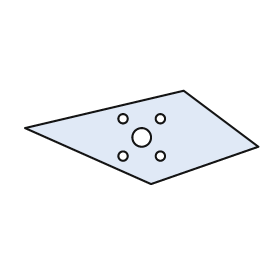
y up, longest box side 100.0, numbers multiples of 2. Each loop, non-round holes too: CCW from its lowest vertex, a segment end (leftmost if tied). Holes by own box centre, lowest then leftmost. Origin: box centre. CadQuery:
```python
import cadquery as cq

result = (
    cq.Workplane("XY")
    .moveTo(4.0, -20.0)
    .lineTo(50.0, -4.0)
    .lineTo(18.0, 20.0)
    .lineTo(-50.0, 4.0)
    .close()
    .moveTo(-8.0, -8.0)
    .circle(2.0)
    .moveTo(8.0, -8.0)
    .circle(2.0)
    .moveTo(0.0, 0.0)
    .circle(4.0)
    .moveTo(-8.0, 8.0)
    .circle(2.0)
    .moveTo(8.0, 8.0)
    .circle(2.0)
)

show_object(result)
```